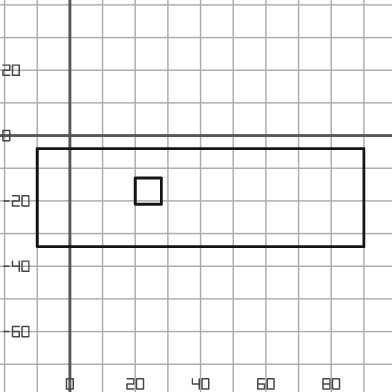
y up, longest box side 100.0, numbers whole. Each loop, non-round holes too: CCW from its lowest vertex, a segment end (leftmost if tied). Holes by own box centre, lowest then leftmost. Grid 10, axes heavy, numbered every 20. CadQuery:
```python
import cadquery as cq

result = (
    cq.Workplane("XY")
    .moveTo(-10.0, -34.0)
    .lineTo(90.0, -34.0)
    .lineTo(90.0, -4.0)
    .lineTo(-10.0, -4.0)
    .close()
    .moveTo(20.0, -21.0)
    .lineTo(28.0, -21.0)
    .lineTo(28.0, -13.0)
    .lineTo(20.0, -13.0)
    .close()
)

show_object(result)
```